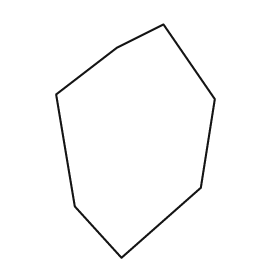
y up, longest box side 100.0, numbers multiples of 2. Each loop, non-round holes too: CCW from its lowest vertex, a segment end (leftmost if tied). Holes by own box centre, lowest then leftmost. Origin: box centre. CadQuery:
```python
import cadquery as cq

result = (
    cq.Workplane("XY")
    .moveTo(-6.0, -50.0)
    .lineTo(28.0, -20.0)
    .lineTo(34.0, 18.0)
    .lineTo(12.0, 50.0)
    .lineTo(-8.0, 40.0)
    .lineTo(-34.0, 20.0)
    .lineTo(-26.0, -28.0)
    .close()
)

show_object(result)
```